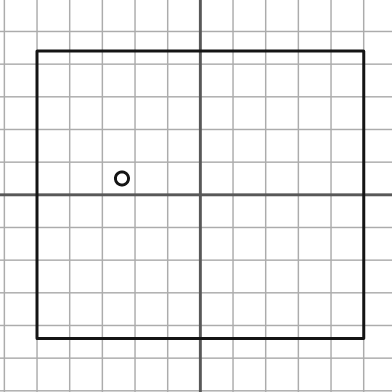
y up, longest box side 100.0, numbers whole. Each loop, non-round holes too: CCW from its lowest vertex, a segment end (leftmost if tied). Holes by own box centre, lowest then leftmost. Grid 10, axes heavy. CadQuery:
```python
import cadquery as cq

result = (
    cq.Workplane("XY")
    .moveTo(-50.0, -44.0)
    .lineTo(50.0, -44.0)
    .lineTo(50.0, 44.0)
    .lineTo(-50.0, 44.0)
    .close()
    .moveTo(-24.0, 5.0)
    .circle(2.0)
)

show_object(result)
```